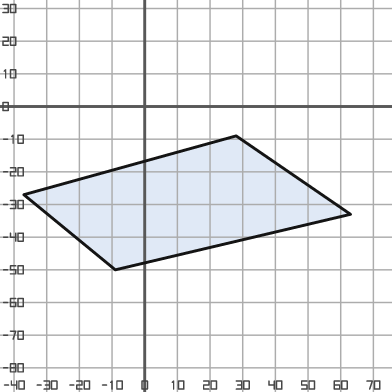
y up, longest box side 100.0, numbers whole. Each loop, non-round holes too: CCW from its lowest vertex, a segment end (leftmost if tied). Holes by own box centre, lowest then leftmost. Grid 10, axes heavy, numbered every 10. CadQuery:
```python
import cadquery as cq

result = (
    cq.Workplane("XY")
    .moveTo(-9.0, -50.0)
    .lineTo(63.0, -33.0)
    .lineTo(28.0, -9.0)
    .lineTo(-37.0, -27.0)
    .close()
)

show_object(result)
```